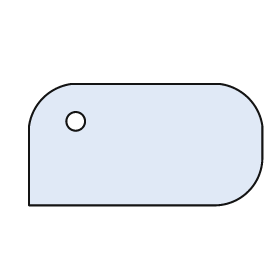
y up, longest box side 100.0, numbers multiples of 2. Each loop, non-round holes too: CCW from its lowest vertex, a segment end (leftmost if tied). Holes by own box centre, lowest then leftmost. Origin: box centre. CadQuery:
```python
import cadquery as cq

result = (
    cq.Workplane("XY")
    .moveTo(-50.0, -26.0)
    .lineTo(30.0, -26.0)
    .threePointArc((44.0, -20.0), (50.0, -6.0))
    .lineTo(50.0, 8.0)
    .threePointArc((44.0, 20.0), (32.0, 26.0))
    .lineTo(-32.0, 26.0)
    .threePointArc((-44.0, 20.0), (-50.0, 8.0))
    .close()
    .moveTo(-30.0, 10.0)
    .circle(4.0)
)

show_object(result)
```